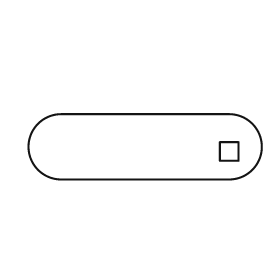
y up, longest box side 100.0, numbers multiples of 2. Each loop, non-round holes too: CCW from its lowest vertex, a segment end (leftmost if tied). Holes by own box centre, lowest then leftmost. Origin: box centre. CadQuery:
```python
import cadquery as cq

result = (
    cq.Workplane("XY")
    .moveTo(-36.0, -14.0)
    .lineTo(36.0, -14.0)
    .threePointArc((50.0, 0.0), (36.0, 14.0))
    .lineTo(-36.0, 14.0)
    .threePointArc((-50.0, 0.0), (-36.0, -14.0))
    .close()
    .moveTo(32.0, -6.0)
    .lineTo(40.0, -6.0)
    .lineTo(40.0, 2.0)
    .lineTo(32.0, 2.0)
    .close()
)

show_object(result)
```